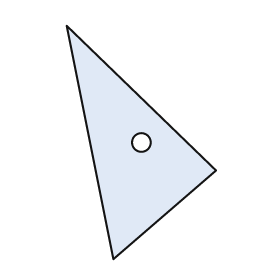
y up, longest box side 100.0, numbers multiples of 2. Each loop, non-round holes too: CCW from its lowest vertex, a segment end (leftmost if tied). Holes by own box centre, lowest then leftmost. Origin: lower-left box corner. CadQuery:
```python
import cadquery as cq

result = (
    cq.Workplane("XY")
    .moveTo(20.0, 0.0)
    .lineTo(64.0, 38.0)
    .lineTo(0.0, 100.0)
    .close()
    .moveTo(32.0, 50.0)
    .circle(4.0)
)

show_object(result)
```